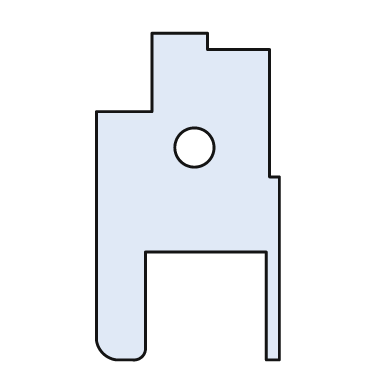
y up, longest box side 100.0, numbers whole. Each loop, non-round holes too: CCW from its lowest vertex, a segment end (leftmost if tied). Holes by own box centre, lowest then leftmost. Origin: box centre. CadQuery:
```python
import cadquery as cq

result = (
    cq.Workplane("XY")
    .moveTo(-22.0, -50.0)
    .lineTo(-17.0, -50.0)
    .threePointArc((-14.0, -49.0), (-13.0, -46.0))
    .lineTo(-13.0, -17.0)
    .lineTo(24.0, -17.0)
    .lineTo(24.0, -50.0)
    .lineTo(28.0, -50.0)
    .lineTo(28.0, 6.0)
    .lineTo(25.0, 6.0)
    .lineTo(25.0, 45.0)
    .lineTo(6.0, 45.0)
    .lineTo(6.0, 50.0)
    .lineTo(-11.0, 50.0)
    .lineTo(-11.0, 26.0)
    .lineTo(-28.0, 26.0)
    .lineTo(-28.0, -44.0)
    .threePointArc((-26.0, -48.0), (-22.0, -50.0))
    .close()
    .moveTo(2.0, 15.0)
    .circle(6.0)
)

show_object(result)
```